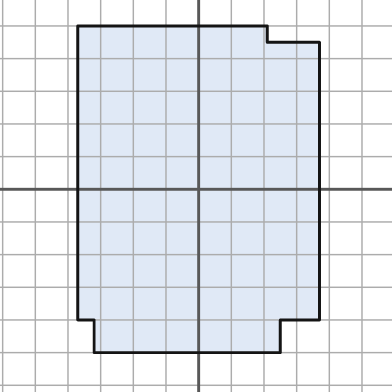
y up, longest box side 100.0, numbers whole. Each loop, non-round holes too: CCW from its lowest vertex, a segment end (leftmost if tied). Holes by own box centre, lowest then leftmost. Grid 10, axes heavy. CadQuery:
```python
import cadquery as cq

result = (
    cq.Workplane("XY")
    .moveTo(-32.0, -50.0)
    .lineTo(25.0, -50.0)
    .lineTo(25.0, -40.0)
    .lineTo(37.0, -40.0)
    .lineTo(37.0, 45.0)
    .lineTo(21.0, 45.0)
    .lineTo(21.0, 50.0)
    .lineTo(-37.0, 50.0)
    .lineTo(-37.0, -40.0)
    .lineTo(-32.0, -40.0)
    .close()
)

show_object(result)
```